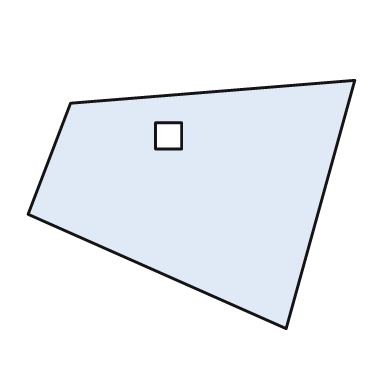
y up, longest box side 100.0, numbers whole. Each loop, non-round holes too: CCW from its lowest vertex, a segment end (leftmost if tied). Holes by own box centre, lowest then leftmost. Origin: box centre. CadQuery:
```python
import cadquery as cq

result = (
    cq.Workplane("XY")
    .moveTo(29.0, -38.0)
    .lineTo(50.0, 38.0)
    .lineTo(-37.0, 31.0)
    .lineTo(-50.0, -3.0)
    .close()
    .moveTo(-11.0, 17.0)
    .lineTo(-3.0, 17.0)
    .lineTo(-3.0, 25.0)
    .lineTo(-11.0, 25.0)
    .close()
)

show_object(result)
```